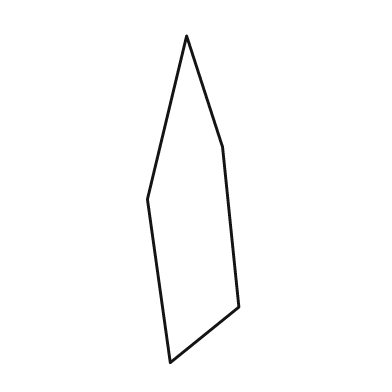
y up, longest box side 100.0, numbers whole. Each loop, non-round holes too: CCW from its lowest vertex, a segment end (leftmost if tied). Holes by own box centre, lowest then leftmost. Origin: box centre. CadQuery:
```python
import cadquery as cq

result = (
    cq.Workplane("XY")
    .moveTo(-7.0, -50.0)
    .lineTo(14.0, -33.0)
    .lineTo(9.0, 16.0)
    .lineTo(-2.0, 50.0)
    .lineTo(-14.0, 0.0)
    .close()
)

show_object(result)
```